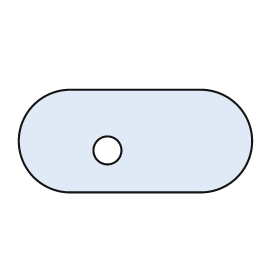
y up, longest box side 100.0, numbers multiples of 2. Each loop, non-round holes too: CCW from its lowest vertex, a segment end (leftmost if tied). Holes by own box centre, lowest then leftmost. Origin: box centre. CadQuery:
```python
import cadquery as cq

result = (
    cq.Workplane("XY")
    .moveTo(-28.0, -22.0)
    .lineTo(28.0, -22.0)
    .threePointArc((50.0, 0.0), (28.0, 22.0))
    .lineTo(-28.0, 22.0)
    .threePointArc((-50.0, 0.0), (-28.0, -22.0))
    .close()
    .moveTo(-12.0, -4.0)
    .circle(6.0)
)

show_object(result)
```